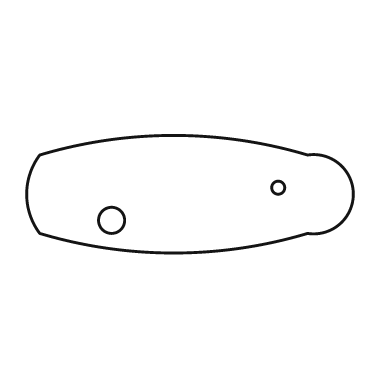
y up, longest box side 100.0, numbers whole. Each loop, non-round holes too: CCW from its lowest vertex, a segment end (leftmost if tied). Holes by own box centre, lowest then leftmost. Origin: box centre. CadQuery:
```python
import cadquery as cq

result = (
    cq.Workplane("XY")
    .moveTo(-46.0, -12.0)
    .threePointArc((-5.0, -18.0), (36.0, -12.0))
    .threePointArc((50.0, 0.0), (36.0, 12.0))
    .threePointArc((-5.0, 18.0), (-46.0, 12.0))
    .threePointArc((-50.0, 0.0), (-46.0, -12.0))
    .close()
    .moveTo(-24.0, -8.0)
    .circle(4.0)
    .moveTo(27.0, 2.0)
    .circle(2.0)
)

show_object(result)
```